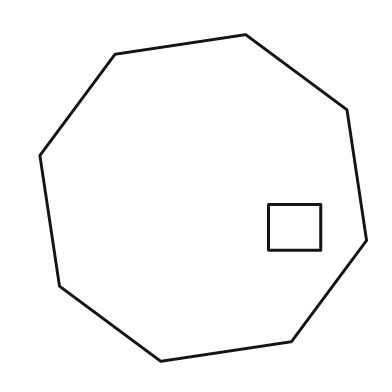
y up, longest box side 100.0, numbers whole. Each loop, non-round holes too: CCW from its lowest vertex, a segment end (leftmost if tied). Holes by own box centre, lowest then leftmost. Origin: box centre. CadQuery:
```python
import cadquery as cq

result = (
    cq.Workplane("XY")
    .moveTo(-13.0, -50.0)
    .lineTo(27.0, -44.0)
    .lineTo(50.0, -13.0)
    .lineTo(44.0, 27.0)
    .lineTo(13.0, 50.0)
    .lineTo(-27.0, 44.0)
    .lineTo(-50.0, 13.0)
    .lineTo(-44.0, -27.0)
    .close()
    .moveTo(20.0, -16.0)
    .lineTo(36.0, -16.0)
    .lineTo(36.0, -2.0)
    .lineTo(20.0, -2.0)
    .close()
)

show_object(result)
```